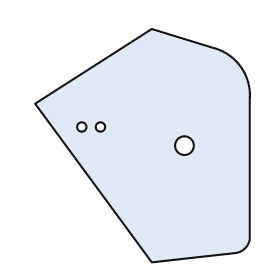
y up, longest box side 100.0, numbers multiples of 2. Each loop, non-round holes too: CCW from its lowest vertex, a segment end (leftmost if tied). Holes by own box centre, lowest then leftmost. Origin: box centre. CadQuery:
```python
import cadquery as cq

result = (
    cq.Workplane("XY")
    .moveTo(4.0, -50.0)
    .lineTo(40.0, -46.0)
    .threePointArc((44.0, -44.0), (46.0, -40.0))
    .lineTo(46.0, 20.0)
    .threePointArc((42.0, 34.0), (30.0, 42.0))
    .lineTo(4.0, 50.0)
    .lineTo(-46.0, 18.0)
    .close()
    .moveTo(18.0, 0.0)
    .circle(4.0)
    .moveTo(-26.0, 8.0)
    .circle(2.0)
    .moveTo(-18.0, 8.0)
    .circle(2.0)
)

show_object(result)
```